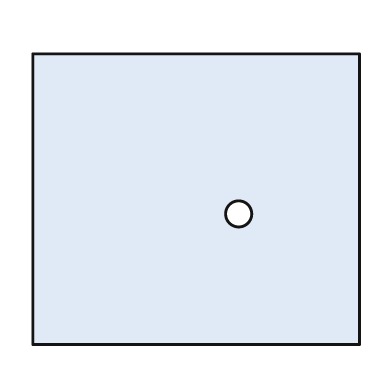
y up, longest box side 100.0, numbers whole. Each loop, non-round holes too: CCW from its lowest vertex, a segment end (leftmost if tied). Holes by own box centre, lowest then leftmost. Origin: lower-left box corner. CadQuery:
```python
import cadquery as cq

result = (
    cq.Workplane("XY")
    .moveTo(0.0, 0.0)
    .lineTo(100.0, 0.0)
    .lineTo(100.0, 89.0)
    .lineTo(0.0, 89.0)
    .close()
    .moveTo(63.0, 40.0)
    .circle(4.0)
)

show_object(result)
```